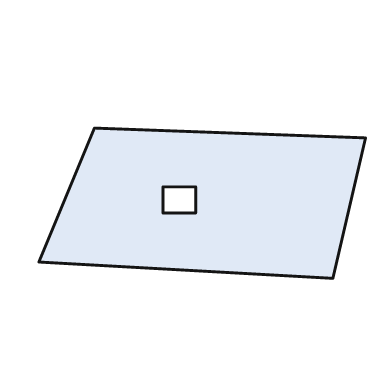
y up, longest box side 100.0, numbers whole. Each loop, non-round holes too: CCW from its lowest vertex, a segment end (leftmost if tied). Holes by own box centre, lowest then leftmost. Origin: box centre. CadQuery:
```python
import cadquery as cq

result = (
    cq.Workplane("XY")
    .moveTo(40.0, -23.0)
    .lineTo(50.0, 20.0)
    .lineTo(-33.0, 23.0)
    .lineTo(-50.0, -18.0)
    .close()
    .moveTo(-12.0, -3.0)
    .lineTo(-2.0, -3.0)
    .lineTo(-2.0, 5.0)
    .lineTo(-12.0, 5.0)
    .close()
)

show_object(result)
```